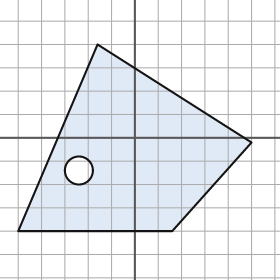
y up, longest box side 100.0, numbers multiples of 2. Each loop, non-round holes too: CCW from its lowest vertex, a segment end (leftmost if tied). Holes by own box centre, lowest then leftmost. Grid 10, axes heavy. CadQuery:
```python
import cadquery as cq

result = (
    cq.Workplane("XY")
    .moveTo(-50.0, -40.0)
    .lineTo(16.0, -40.0)
    .lineTo(50.0, -2.0)
    .lineTo(-16.0, 40.0)
    .close()
    .moveTo(-24.0, -14.0)
    .circle(6.0)
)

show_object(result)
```